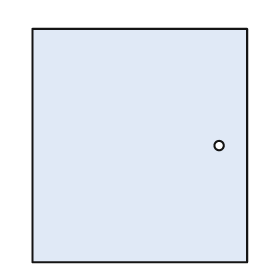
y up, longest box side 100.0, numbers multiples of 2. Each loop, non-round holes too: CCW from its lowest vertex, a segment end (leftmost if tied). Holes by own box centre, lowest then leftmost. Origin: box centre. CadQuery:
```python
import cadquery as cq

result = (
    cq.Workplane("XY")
    .moveTo(-46.0, -50.0)
    .lineTo(46.0, -50.0)
    .lineTo(46.0, 50.0)
    .lineTo(-46.0, 50.0)
    .close()
    .moveTo(34.0, 0.0)
    .circle(2.0)
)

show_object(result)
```